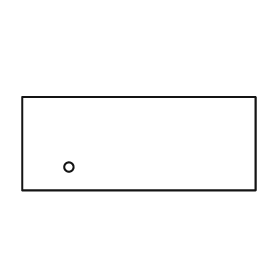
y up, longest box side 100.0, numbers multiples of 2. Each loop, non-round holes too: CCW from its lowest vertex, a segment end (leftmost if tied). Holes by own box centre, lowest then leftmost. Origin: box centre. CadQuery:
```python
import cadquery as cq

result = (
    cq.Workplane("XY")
    .moveTo(-50.0, -20.0)
    .lineTo(50.0, -20.0)
    .lineTo(50.0, 20.0)
    .lineTo(-50.0, 20.0)
    .close()
    .moveTo(-30.0, -10.0)
    .circle(2.0)
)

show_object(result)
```